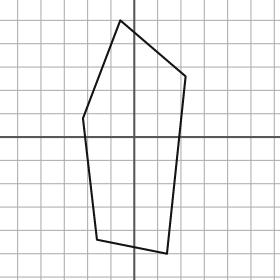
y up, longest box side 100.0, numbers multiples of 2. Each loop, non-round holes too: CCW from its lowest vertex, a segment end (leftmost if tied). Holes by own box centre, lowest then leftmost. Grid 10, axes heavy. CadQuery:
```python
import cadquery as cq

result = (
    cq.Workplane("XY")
    .moveTo(14.0, -50.0)
    .lineTo(22.0, 26.0)
    .lineTo(-6.0, 50.0)
    .lineTo(-22.0, 8.0)
    .lineTo(-16.0, -44.0)
    .close()
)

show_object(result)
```